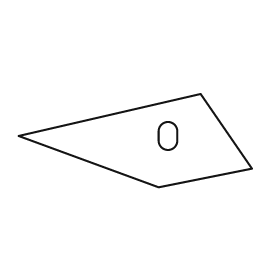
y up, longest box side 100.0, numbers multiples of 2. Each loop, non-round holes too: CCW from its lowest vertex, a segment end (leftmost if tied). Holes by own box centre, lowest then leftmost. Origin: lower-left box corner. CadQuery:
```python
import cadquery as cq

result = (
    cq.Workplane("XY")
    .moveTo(60.0, 0.0)
    .lineTo(100.0, 8.0)
    .lineTo(78.0, 40.0)
    .lineTo(0.0, 22.0)
    .close()
    .moveTo(60.0, 20.0)
    .threePointArc((64.0, 16.0), (68.0, 20.0))
    .lineTo(68.0, 24.0)
    .threePointArc((64.0, 28.0), (60.0, 24.0))
    .close()
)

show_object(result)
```